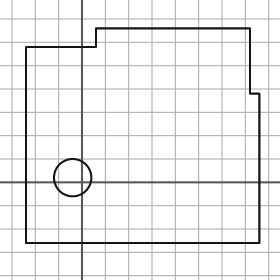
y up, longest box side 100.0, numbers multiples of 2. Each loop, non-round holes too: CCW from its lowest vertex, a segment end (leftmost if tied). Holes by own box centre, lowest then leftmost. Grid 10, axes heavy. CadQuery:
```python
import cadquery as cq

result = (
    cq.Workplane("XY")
    .moveTo(-24.0, -26.0)
    .lineTo(76.0, -26.0)
    .lineTo(76.0, 38.0)
    .lineTo(72.0, 38.0)
    .lineTo(72.0, 66.0)
    .lineTo(6.0, 66.0)
    .lineTo(6.0, 58.0)
    .lineTo(-24.0, 58.0)
    .close()
    .moveTo(-4.0, 2.0)
    .circle(8.0)
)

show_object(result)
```